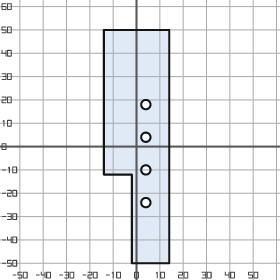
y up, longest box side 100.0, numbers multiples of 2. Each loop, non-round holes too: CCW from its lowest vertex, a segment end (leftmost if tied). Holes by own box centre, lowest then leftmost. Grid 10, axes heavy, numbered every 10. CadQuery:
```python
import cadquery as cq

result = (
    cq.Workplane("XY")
    .moveTo(-2.0, -50.0)
    .lineTo(14.0, -50.0)
    .lineTo(14.0, 50.0)
    .lineTo(-14.0, 50.0)
    .lineTo(-14.0, -12.0)
    .lineTo(-2.0, -12.0)
    .close()
    .moveTo(4.0, -24.0)
    .circle(2.0)
    .moveTo(4.0, -10.0)
    .circle(2.0)
    .moveTo(4.0, 4.0)
    .circle(2.0)
    .moveTo(4.0, 18.0)
    .circle(2.0)
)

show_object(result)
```